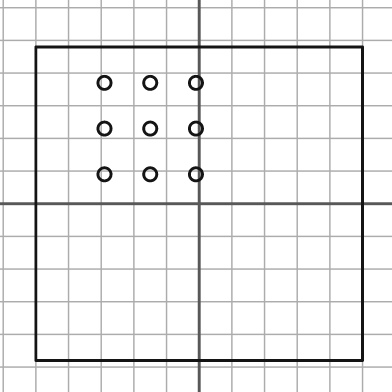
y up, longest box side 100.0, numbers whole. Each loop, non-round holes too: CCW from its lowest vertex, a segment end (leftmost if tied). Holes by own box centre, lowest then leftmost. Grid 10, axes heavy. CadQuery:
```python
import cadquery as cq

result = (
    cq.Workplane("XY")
    .moveTo(-50.0, -48.0)
    .lineTo(50.0, -48.0)
    .lineTo(50.0, 48.0)
    .lineTo(-50.0, 48.0)
    .close()
    .moveTo(-29.0, 9.0)
    .circle(2.0)
    .moveTo(-15.0, 9.0)
    .circle(2.0)
    .moveTo(-1.0, 9.0)
    .circle(2.0)
    .moveTo(-29.0, 23.0)
    .circle(2.0)
    .moveTo(-15.0, 23.0)
    .circle(2.0)
    .moveTo(-1.0, 23.0)
    .circle(2.0)
    .moveTo(-29.0, 37.0)
    .circle(2.0)
    .moveTo(-15.0, 37.0)
    .circle(2.0)
    .moveTo(-1.0, 37.0)
    .circle(2.0)
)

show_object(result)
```